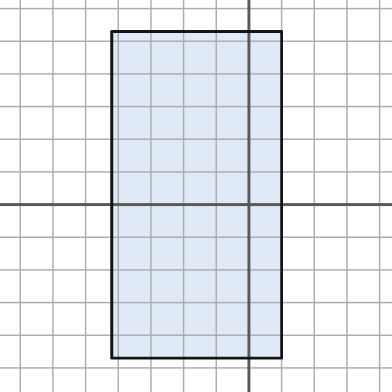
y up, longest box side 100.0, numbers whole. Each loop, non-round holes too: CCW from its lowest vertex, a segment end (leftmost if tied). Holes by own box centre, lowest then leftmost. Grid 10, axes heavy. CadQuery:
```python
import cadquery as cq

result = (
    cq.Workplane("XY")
    .moveTo(-42.0, -47.0)
    .lineTo(10.0, -47.0)
    .lineTo(10.0, 53.0)
    .lineTo(-42.0, 53.0)
    .close()
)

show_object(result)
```